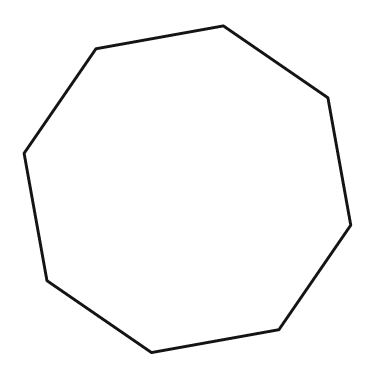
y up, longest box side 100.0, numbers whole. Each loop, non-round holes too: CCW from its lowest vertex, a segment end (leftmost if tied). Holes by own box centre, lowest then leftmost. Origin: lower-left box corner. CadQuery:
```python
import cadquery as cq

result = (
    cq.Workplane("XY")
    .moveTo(39.0, 0.0)
    .lineTo(78.0, 7.0)
    .lineTo(100.0, 39.0)
    .lineTo(93.0, 78.0)
    .lineTo(61.0, 100.0)
    .lineTo(22.0, 93.0)
    .lineTo(0.0, 61.0)
    .lineTo(7.0, 22.0)
    .close()
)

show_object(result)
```